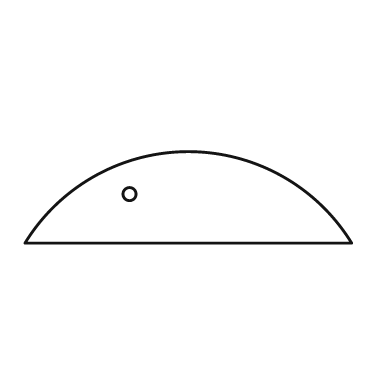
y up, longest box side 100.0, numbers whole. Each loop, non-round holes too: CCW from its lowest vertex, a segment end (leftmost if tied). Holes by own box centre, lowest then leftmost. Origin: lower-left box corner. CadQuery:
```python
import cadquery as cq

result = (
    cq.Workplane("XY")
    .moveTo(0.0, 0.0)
    .lineTo(100.0, 0.0)
    .threePointArc((50.0, 28.0), (0.0, 0.0))
    .close()
    .moveTo(32.0, 15.0)
    .circle(2.0)
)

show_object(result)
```